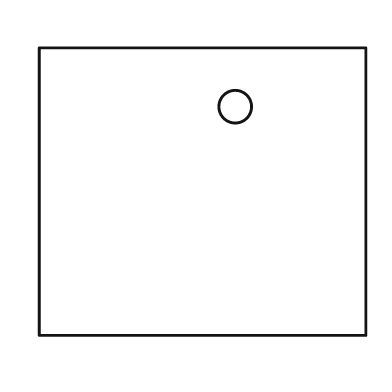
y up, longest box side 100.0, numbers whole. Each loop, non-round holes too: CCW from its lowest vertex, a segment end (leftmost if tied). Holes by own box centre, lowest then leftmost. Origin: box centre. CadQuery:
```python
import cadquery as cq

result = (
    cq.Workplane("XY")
    .moveTo(-50.0, -44.0)
    .lineTo(50.0, -44.0)
    .lineTo(50.0, 44.0)
    .lineTo(-50.0, 44.0)
    .close()
    .moveTo(10.0, 26.0)
    .circle(5.0)
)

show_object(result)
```